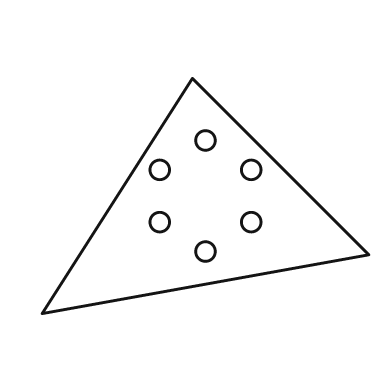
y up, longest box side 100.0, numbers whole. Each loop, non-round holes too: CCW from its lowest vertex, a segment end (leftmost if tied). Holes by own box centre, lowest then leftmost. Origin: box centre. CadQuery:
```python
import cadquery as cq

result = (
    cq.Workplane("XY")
    .moveTo(-50.0, -36.0)
    .lineTo(50.0, -18.0)
    .lineTo(-4.0, 36.0)
    .close()
    .moveTo(0.0, -17.0)
    .circle(3.0)
    .moveTo(-14.0, -8.0)
    .circle(3.0)
    .moveTo(14.0, -8.0)
    .circle(3.0)
    .moveTo(-14.0, 8.0)
    .circle(3.0)
    .moveTo(14.0, 8.0)
    .circle(3.0)
    .moveTo(0.0, 17.0)
    .circle(3.0)
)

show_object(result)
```